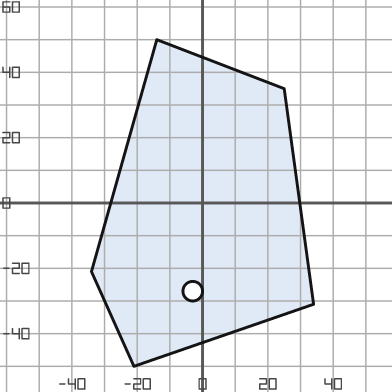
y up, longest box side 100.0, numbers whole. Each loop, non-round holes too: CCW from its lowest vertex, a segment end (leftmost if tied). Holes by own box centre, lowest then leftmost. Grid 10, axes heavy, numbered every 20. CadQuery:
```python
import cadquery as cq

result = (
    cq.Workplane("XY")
    .moveTo(-21.0, -50.0)
    .lineTo(34.0, -31.0)
    .lineTo(25.0, 35.0)
    .lineTo(-14.0, 50.0)
    .lineTo(-34.0, -21.0)
    .close()
    .moveTo(-3.0, -27.0)
    .circle(3.0)
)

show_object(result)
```